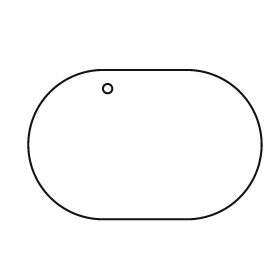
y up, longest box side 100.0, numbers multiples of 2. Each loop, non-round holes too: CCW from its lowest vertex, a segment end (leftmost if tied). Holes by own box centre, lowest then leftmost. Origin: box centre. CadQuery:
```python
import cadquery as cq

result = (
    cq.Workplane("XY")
    .moveTo(-18.0, -32.0)
    .lineTo(18.0, -32.0)
    .threePointArc((50.0, 0.0), (18.0, 32.0))
    .lineTo(-18.0, 32.0)
    .threePointArc((-50.0, 0.0), (-18.0, -32.0))
    .close()
    .moveTo(-16.0, 24.0)
    .circle(2.0)
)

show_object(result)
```